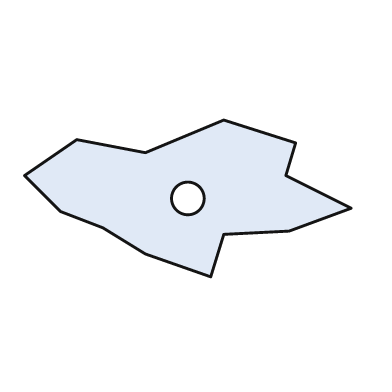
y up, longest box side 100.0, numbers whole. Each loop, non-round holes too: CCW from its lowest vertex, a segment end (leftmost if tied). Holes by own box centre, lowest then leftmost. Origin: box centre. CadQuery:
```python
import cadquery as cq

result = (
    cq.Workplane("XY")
    .moveTo(7.0, -24.0)
    .lineTo(11.0, -11.0)
    .lineTo(31.0, -10.0)
    .lineTo(50.0, -3.0)
    .lineTo(30.0, 7.0)
    .lineTo(33.0, 17.0)
    .lineTo(11.0, 24.0)
    .lineTo(-13.0, 14.0)
    .lineTo(-34.0, 18.0)
    .lineTo(-50.0, 7.0)
    .lineTo(-39.0, -4.0)
    .lineTo(-26.0, -9.0)
    .lineTo(-13.0, -17.0)
    .close()
    .moveTo(0.0, 0.0)
    .circle(5.0)
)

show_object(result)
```